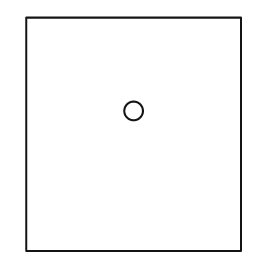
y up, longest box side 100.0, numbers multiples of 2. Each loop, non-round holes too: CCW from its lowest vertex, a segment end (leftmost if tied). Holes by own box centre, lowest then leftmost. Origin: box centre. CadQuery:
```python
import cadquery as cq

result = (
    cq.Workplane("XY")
    .moveTo(-46.0, -50.0)
    .lineTo(46.0, -50.0)
    .lineTo(46.0, 50.0)
    .lineTo(-46.0, 50.0)
    .close()
    .moveTo(0.0, 10.0)
    .circle(4.0)
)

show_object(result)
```